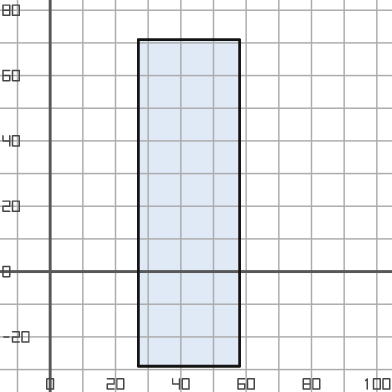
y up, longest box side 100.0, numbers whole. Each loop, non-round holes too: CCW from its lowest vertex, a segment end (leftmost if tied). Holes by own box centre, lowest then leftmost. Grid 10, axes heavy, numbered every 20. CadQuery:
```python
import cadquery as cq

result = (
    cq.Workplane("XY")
    .moveTo(27.0, -29.0)
    .lineTo(58.0, -29.0)
    .lineTo(58.0, 71.0)
    .lineTo(27.0, 71.0)
    .close()
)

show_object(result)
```